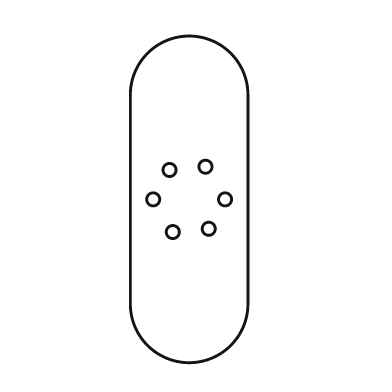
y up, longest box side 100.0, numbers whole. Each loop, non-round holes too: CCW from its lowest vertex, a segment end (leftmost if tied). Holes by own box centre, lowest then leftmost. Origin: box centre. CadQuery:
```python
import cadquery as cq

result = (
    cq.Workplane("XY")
    .moveTo(-18.0, -32.0)
    .threePointArc((0.0, -50.0), (18.0, -32.0))
    .lineTo(18.0, 32.0)
    .threePointArc((0.0, 50.0), (-18.0, 32.0))
    .close()
    .moveTo(-5.0, -10.0)
    .circle(2.0)
    .moveTo(6.0, -9.0)
    .circle(2.0)
    .moveTo(-11.0, 0.0)
    .circle(2.0)
    .moveTo(11.0, 0.0)
    .circle(2.0)
    .moveTo(-6.0, 9.0)
    .circle(2.0)
    .moveTo(5.0, 10.0)
    .circle(2.0)
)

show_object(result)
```